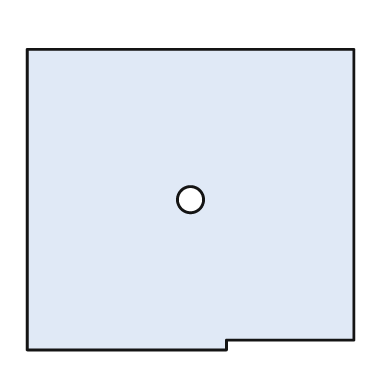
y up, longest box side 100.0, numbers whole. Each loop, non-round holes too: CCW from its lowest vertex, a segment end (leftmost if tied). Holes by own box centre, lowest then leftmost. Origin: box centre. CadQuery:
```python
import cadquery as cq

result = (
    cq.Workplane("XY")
    .moveTo(-50.0, -46.0)
    .lineTo(11.0, -46.0)
    .lineTo(11.0, -43.0)
    .lineTo(50.0, -43.0)
    .lineTo(50.0, 46.0)
    .lineTo(-50.0, 46.0)
    .close()
    .moveTo(0.0, 0.0)
    .circle(4.0)
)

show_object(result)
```